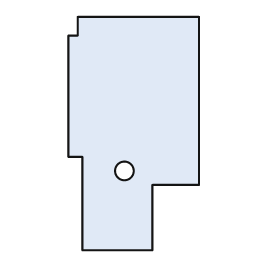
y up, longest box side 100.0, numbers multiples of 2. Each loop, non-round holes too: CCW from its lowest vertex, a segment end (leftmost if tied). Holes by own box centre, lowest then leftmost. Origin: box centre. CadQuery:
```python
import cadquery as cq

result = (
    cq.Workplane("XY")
    .moveTo(-22.0, -50.0)
    .lineTo(8.0, -50.0)
    .lineTo(8.0, -22.0)
    .lineTo(28.0, -22.0)
    .lineTo(28.0, 50.0)
    .lineTo(-24.0, 50.0)
    .lineTo(-24.0, 42.0)
    .lineTo(-28.0, 42.0)
    .lineTo(-28.0, -10.0)
    .lineTo(-22.0, -10.0)
    .close()
    .moveTo(-4.0, -16.0)
    .circle(4.0)
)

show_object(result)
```